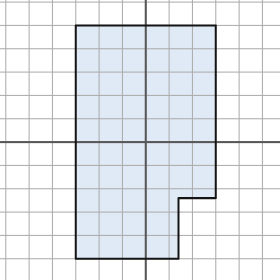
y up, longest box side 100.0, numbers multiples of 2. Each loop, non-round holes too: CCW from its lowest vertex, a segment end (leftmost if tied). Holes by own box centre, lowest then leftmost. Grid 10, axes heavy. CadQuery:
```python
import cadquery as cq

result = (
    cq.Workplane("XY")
    .moveTo(-30.0, -50.0)
    .lineTo(14.0, -50.0)
    .lineTo(14.0, -24.0)
    .lineTo(30.0, -24.0)
    .lineTo(30.0, 50.0)
    .lineTo(-30.0, 50.0)
    .close()
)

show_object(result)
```